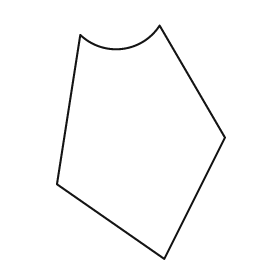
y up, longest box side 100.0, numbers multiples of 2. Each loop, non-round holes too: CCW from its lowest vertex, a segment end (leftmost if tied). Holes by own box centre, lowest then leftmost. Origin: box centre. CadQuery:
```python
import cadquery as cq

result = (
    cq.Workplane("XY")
    .moveTo(10.0, -50.0)
    .lineTo(36.0, 2.0)
    .lineTo(8.0, 50.0)
    .threePointArc((-8.0, 40.0), (-26.0, 46.0))
    .lineTo(-36.0, -18.0)
    .close()
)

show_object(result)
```